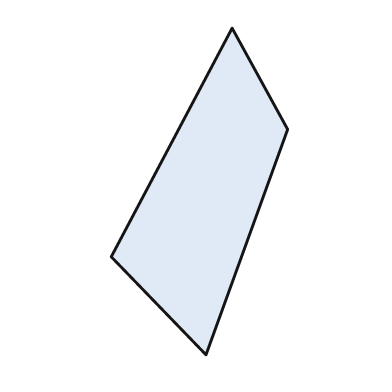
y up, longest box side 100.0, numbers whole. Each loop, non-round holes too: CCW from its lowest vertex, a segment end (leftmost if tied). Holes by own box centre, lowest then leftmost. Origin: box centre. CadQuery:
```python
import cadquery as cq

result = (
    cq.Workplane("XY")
    .moveTo(2.0, -50.0)
    .lineTo(27.0, 19.0)
    .lineTo(10.0, 50.0)
    .lineTo(-27.0, -20.0)
    .close()
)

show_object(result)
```